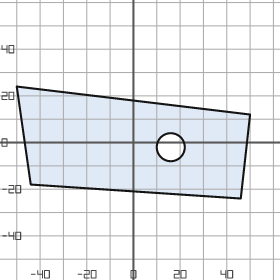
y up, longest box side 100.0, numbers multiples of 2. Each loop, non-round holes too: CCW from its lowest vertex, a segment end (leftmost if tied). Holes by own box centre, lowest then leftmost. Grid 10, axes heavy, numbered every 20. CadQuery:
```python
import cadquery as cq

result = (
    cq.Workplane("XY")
    .moveTo(46.0, -24.0)
    .lineTo(50.0, 12.0)
    .lineTo(-50.0, 24.0)
    .lineTo(-44.0, -18.0)
    .close()
    .moveTo(16.0, -2.0)
    .circle(6.0)
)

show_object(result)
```